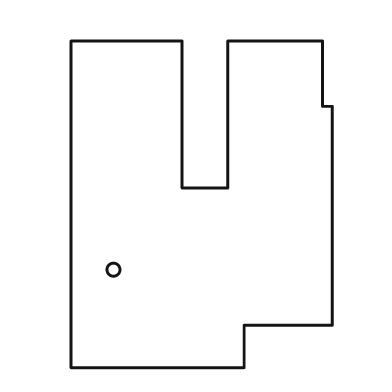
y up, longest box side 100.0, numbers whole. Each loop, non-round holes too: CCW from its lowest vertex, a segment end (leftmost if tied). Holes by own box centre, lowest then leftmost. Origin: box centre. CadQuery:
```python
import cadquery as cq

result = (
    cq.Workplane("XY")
    .moveTo(-40.0, -50.0)
    .lineTo(13.0, -50.0)
    .lineTo(13.0, -37.0)
    .lineTo(40.0, -37.0)
    .lineTo(40.0, 30.0)
    .lineTo(37.0, 30.0)
    .lineTo(37.0, 50.0)
    .lineTo(8.0, 50.0)
    .lineTo(8.0, 5.0)
    .lineTo(-6.0, 5.0)
    .lineTo(-6.0, 50.0)
    .lineTo(-40.0, 50.0)
    .close()
    .moveTo(-27.0, -20.0)
    .circle(2.0)
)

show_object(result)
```